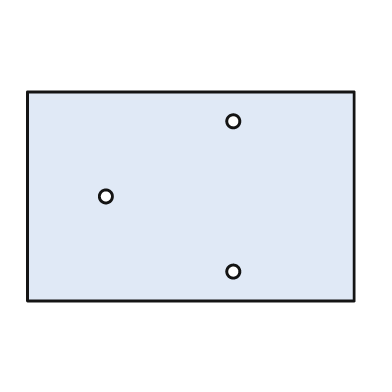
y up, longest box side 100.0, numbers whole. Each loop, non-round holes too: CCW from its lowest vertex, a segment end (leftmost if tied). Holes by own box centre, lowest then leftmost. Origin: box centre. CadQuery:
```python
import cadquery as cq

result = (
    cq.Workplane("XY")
    .moveTo(-50.0, -32.0)
    .lineTo(50.0, -32.0)
    .lineTo(50.0, 32.0)
    .lineTo(-50.0, 32.0)
    .close()
    .moveTo(13.0, -23.0)
    .circle(2.0)
    .moveTo(-26.0, 0.0)
    .circle(2.0)
    .moveTo(13.0, 23.0)
    .circle(2.0)
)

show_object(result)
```